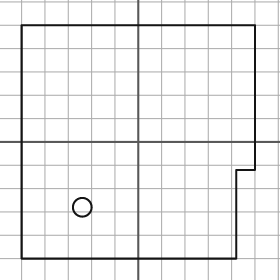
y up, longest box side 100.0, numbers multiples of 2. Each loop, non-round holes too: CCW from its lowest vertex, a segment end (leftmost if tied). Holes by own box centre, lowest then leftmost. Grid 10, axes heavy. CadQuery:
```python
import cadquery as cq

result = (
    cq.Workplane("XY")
    .moveTo(-50.0, -50.0)
    .lineTo(42.0, -50.0)
    .lineTo(42.0, -12.0)
    .lineTo(50.0, -12.0)
    .lineTo(50.0, 50.0)
    .lineTo(-50.0, 50.0)
    .close()
    .moveTo(-24.0, -28.0)
    .circle(4.0)
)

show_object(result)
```